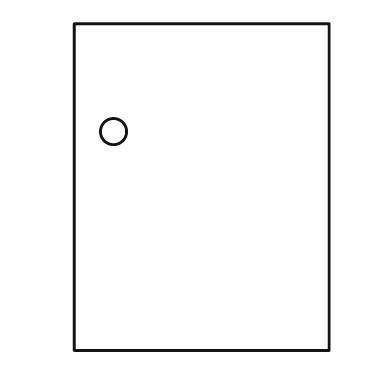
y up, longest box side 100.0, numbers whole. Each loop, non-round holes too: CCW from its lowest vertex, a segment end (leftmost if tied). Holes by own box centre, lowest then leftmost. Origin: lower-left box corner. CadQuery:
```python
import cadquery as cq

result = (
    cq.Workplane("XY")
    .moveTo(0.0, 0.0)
    .lineTo(78.0, 0.0)
    .lineTo(78.0, 100.0)
    .lineTo(0.0, 100.0)
    .close()
    .moveTo(12.0, 67.0)
    .circle(4.0)
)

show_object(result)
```